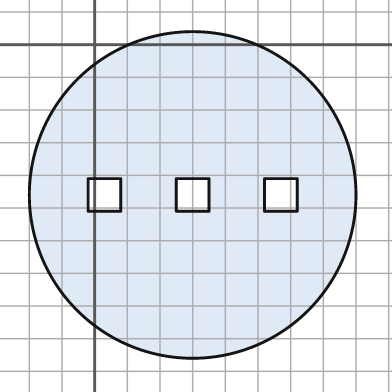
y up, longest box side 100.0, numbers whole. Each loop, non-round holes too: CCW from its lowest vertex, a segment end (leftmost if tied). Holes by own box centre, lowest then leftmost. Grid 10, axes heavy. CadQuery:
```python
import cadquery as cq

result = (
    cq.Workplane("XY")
    .moveTo(30.0, -46.0)
    .circle(50.0)
    .moveTo(-2.0, -51.0)
    .lineTo(8.0, -51.0)
    .lineTo(8.0, -41.0)
    .lineTo(-2.0, -41.0)
    .close()
    .moveTo(25.0, -51.0)
    .lineTo(35.0, -51.0)
    .lineTo(35.0, -41.0)
    .lineTo(25.0, -41.0)
    .close()
    .moveTo(52.0, -51.0)
    .lineTo(62.0, -51.0)
    .lineTo(62.0, -41.0)
    .lineTo(52.0, -41.0)
    .close()
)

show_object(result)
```